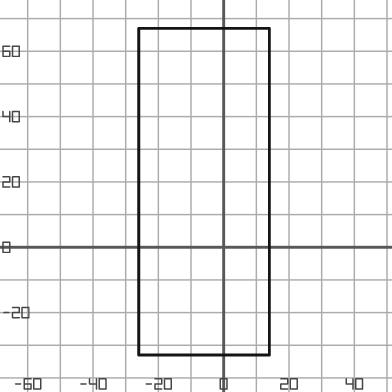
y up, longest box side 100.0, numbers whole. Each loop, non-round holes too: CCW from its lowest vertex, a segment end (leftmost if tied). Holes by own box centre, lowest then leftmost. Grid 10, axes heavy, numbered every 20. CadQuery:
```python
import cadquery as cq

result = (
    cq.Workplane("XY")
    .moveTo(-26.0, -33.0)
    .lineTo(14.0, -33.0)
    .lineTo(14.0, 67.0)
    .lineTo(-26.0, 67.0)
    .close()
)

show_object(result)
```